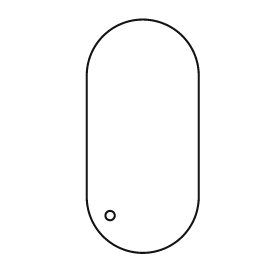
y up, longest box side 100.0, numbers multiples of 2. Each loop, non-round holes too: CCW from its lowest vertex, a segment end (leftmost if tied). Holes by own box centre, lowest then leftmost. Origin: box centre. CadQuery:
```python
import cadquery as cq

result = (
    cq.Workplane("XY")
    .moveTo(-24.0, -26.0)
    .threePointArc((0.0, -50.0), (24.0, -26.0))
    .lineTo(24.0, 26.0)
    .threePointArc((0.0, 50.0), (-24.0, 26.0))
    .close()
    .moveTo(-14.0, -34.0)
    .circle(2.0)
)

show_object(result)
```